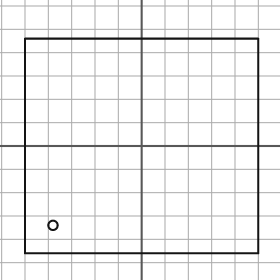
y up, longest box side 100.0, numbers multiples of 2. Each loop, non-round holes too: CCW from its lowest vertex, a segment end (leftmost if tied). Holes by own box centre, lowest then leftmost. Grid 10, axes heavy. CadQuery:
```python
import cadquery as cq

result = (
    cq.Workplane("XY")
    .moveTo(-50.0, -46.0)
    .lineTo(50.0, -46.0)
    .lineTo(50.0, 46.0)
    .lineTo(-50.0, 46.0)
    .close()
    .moveTo(-38.0, -34.0)
    .circle(2.0)
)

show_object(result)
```